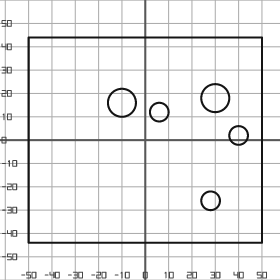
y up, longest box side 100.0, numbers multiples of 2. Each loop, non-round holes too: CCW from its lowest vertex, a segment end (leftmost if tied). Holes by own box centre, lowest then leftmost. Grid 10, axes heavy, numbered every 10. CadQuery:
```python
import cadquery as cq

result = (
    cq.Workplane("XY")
    .moveTo(-50.0, -44.0)
    .lineTo(50.0, -44.0)
    .lineTo(50.0, 44.0)
    .lineTo(-50.0, 44.0)
    .close()
    .moveTo(28.0, -26.0)
    .circle(4.0)
    .moveTo(40.0, 2.0)
    .circle(4.0)
    .moveTo(6.0, 12.0)
    .circle(4.0)
    .moveTo(-10.0, 16.0)
    .circle(6.0)
    .moveTo(30.0, 18.0)
    .circle(6.0)
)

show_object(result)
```